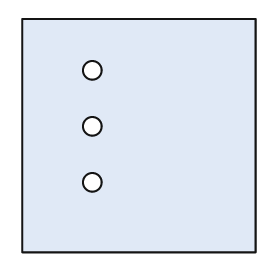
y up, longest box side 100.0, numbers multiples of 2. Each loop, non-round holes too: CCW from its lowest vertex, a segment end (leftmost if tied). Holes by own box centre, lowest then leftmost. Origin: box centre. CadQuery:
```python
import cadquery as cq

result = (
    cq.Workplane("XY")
    .moveTo(-50.0, -50.0)
    .lineTo(50.0, -50.0)
    .lineTo(50.0, 50.0)
    .lineTo(-50.0, 50.0)
    .close()
    .moveTo(-20.0, -20.0)
    .circle(4.0)
    .moveTo(-20.0, 4.0)
    .circle(4.0)
    .moveTo(-20.0, 28.0)
    .circle(4.0)
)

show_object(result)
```